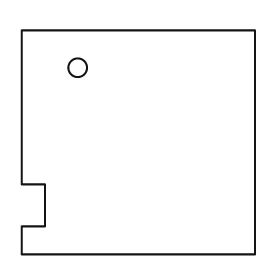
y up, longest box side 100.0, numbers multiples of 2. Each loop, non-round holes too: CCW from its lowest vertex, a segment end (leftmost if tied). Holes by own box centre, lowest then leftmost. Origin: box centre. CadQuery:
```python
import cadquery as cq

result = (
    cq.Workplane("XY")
    .moveTo(-50.0, -48.0)
    .lineTo(50.0, -48.0)
    .lineTo(50.0, 48.0)
    .lineTo(-50.0, 48.0)
    .lineTo(-50.0, -18.0)
    .lineTo(-40.0, -18.0)
    .lineTo(-40.0, -36.0)
    .lineTo(-50.0, -36.0)
    .close()
    .moveTo(-26.0, 32.0)
    .circle(4.0)
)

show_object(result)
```